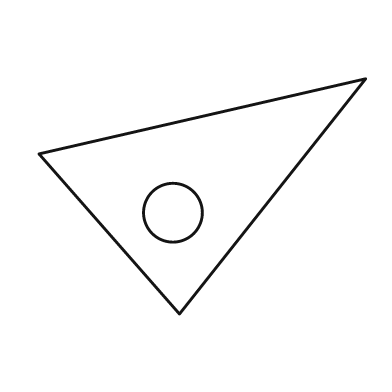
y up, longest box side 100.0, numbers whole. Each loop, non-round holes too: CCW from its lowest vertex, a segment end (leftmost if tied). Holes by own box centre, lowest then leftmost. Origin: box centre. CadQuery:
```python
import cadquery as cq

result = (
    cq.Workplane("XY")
    .moveTo(-7.0, -36.0)
    .lineTo(50.0, 36.0)
    .lineTo(-50.0, 13.0)
    .close()
    .moveTo(-9.0, -5.0)
    .circle(9.0)
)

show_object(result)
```